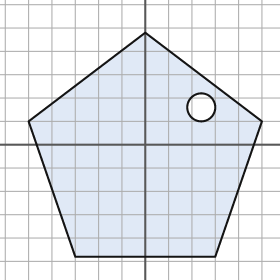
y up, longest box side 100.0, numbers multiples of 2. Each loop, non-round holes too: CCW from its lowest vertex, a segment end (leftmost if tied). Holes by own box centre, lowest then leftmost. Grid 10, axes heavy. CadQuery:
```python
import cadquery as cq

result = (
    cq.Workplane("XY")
    .moveTo(-30.0, -48.0)
    .lineTo(30.0, -48.0)
    .lineTo(50.0, 10.0)
    .lineTo(0.0, 48.0)
    .lineTo(-50.0, 10.0)
    .close()
    .moveTo(24.0, 16.0)
    .circle(6.0)
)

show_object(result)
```